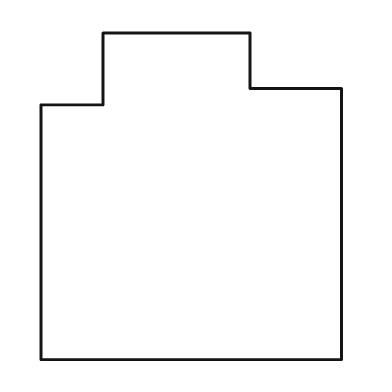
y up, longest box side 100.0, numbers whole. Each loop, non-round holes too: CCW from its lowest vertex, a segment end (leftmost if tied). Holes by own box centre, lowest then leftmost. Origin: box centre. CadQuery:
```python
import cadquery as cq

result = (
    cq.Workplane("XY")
    .moveTo(-46.0, -50.0)
    .lineTo(46.0, -50.0)
    .lineTo(46.0, 33.0)
    .lineTo(18.0, 33.0)
    .lineTo(18.0, 50.0)
    .lineTo(-27.0, 50.0)
    .lineTo(-27.0, 28.0)
    .lineTo(-46.0, 28.0)
    .close()
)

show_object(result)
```